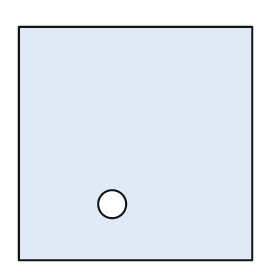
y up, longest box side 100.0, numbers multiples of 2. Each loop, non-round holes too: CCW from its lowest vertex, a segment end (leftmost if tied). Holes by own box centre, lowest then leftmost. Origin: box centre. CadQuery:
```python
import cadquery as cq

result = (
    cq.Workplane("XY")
    .moveTo(-50.0, -50.0)
    .lineTo(50.0, -50.0)
    .lineTo(50.0, 50.0)
    .lineTo(-50.0, 50.0)
    .close()
    .moveTo(-10.0, -26.0)
    .circle(6.0)
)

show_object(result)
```